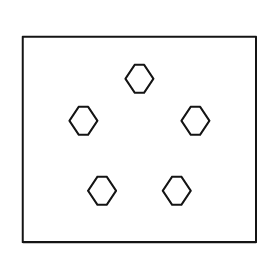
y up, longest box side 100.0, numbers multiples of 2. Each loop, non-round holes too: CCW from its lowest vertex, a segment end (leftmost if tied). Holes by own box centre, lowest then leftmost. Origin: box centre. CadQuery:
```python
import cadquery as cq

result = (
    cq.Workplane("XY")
    .moveTo(-50.0, -44.0)
    .lineTo(50.0, -44.0)
    .lineTo(50.0, 44.0)
    .lineTo(-50.0, 44.0)
    .close()
    .moveTo(-18.0, -28.0)
    .lineTo(-14.0, -28.0)
    .lineTo(-10.0, -22.0)
    .lineTo(-14.0, -16.0)
    .lineTo(-18.0, -16.0)
    .lineTo(-22.0, -22.0)
    .close()
    .moveTo(14.0, -28.0)
    .lineTo(18.0, -28.0)
    .lineTo(22.0, -22.0)
    .lineTo(18.0, -16.0)
    .lineTo(14.0, -16.0)
    .lineTo(10.0, -22.0)
    .close()
    .moveTo(-26.0, 2.0)
    .lineTo(-22.0, 2.0)
    .lineTo(-18.0, 8.0)
    .lineTo(-22.0, 14.0)
    .lineTo(-26.0, 14.0)
    .lineTo(-30.0, 8.0)
    .close()
    .moveTo(22.0, 2.0)
    .lineTo(26.0, 2.0)
    .lineTo(30.0, 8.0)
    .lineTo(26.0, 14.0)
    .lineTo(22.0, 14.0)
    .lineTo(18.0, 8.0)
    .close()
    .moveTo(-2.0, 20.0)
    .lineTo(2.0, 20.0)
    .lineTo(6.0, 26.0)
    .lineTo(2.0, 32.0)
    .lineTo(-2.0, 32.0)
    .lineTo(-6.0, 26.0)
    .close()
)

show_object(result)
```